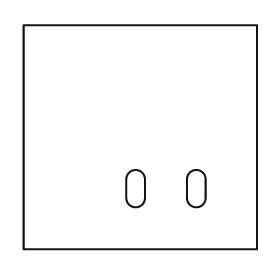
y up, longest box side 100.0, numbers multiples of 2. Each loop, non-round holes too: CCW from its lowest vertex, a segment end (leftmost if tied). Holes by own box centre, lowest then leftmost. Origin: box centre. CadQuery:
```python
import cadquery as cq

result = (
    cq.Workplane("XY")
    .moveTo(-50.0, -48.0)
    .lineTo(50.0, -48.0)
    .lineTo(50.0, 48.0)
    .lineTo(-50.0, 48.0)
    .close()
    .moveTo(-6.0, -26.0)
    .threePointArc((-2.0, -30.0), (2.0, -26.0))
    .lineTo(2.0, -18.0)
    .threePointArc((-2.0, -14.0), (-6.0, -18.0))
    .close()
    .moveTo(20.0, -26.0)
    .threePointArc((24.0, -30.0), (28.0, -26.0))
    .lineTo(28.0, -18.0)
    .threePointArc((24.0, -14.0), (20.0, -18.0))
    .close()
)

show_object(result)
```